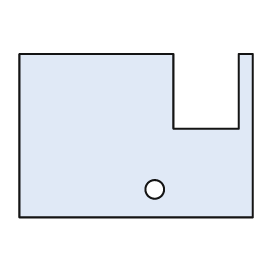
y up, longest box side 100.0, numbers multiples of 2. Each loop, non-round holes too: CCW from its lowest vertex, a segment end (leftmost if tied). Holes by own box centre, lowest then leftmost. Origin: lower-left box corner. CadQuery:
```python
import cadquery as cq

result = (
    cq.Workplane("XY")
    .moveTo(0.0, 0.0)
    .lineTo(100.0, 0.0)
    .lineTo(100.0, 70.0)
    .lineTo(94.0, 70.0)
    .lineTo(94.0, 38.0)
    .lineTo(66.0, 38.0)
    .lineTo(66.0, 70.0)
    .lineTo(0.0, 70.0)
    .close()
    .moveTo(58.0, 12.0)
    .circle(4.0)
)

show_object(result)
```